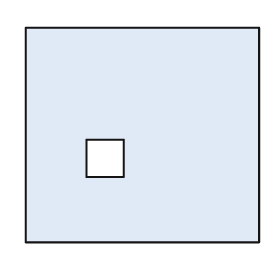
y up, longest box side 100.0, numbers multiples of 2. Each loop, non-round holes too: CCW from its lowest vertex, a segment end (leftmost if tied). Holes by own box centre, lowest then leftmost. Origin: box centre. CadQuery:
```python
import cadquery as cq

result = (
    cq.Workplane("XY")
    .moveTo(-50.0, -46.0)
    .lineTo(50.0, -46.0)
    .lineTo(50.0, 46.0)
    .lineTo(-50.0, 46.0)
    .close()
    .moveTo(-24.0, -18.0)
    .lineTo(-8.0, -18.0)
    .lineTo(-8.0, -2.0)
    .lineTo(-24.0, -2.0)
    .close()
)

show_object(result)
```